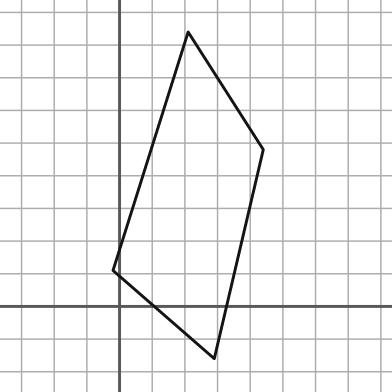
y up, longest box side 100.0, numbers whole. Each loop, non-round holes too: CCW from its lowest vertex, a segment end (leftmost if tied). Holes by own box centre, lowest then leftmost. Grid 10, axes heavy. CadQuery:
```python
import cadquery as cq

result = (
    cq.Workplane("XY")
    .moveTo(29.0, -16.0)
    .lineTo(44.0, 48.0)
    .lineTo(21.0, 84.0)
    .lineTo(-2.0, 11.0)
    .close()
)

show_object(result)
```